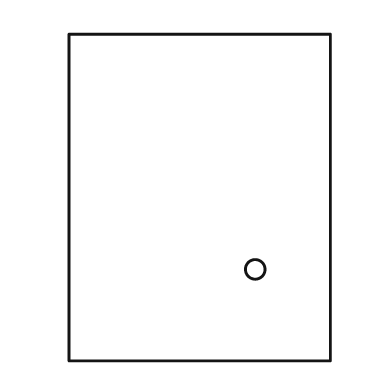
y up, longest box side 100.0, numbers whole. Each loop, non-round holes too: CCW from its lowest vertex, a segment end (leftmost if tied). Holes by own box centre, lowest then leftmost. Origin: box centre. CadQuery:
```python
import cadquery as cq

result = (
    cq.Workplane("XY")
    .moveTo(-40.0, -50.0)
    .lineTo(40.0, -50.0)
    .lineTo(40.0, 50.0)
    .lineTo(-40.0, 50.0)
    .close()
    .moveTo(17.0, -22.0)
    .circle(3.0)
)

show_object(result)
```